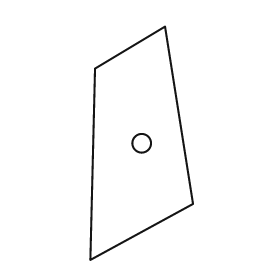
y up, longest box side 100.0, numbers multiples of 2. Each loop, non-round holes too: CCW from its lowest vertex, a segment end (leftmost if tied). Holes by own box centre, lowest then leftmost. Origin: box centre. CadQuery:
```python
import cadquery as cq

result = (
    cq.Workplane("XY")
    .moveTo(-22.0, -50.0)
    .lineTo(22.0, -26.0)
    .lineTo(10.0, 50.0)
    .lineTo(-20.0, 32.0)
    .close()
    .moveTo(0.0, 0.0)
    .circle(4.0)
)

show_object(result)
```